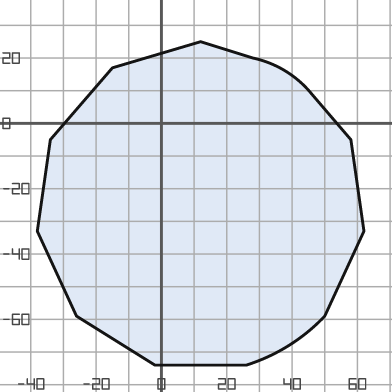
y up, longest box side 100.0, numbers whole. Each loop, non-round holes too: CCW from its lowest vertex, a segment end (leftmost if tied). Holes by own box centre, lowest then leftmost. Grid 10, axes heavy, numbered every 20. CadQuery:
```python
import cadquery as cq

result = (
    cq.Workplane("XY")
    .moveTo(-2.0, -74.0)
    .lineTo(26.0, -74.0)
    .threePointArc((39.0, -68.0), (50.0, -59.0))
    .lineTo(62.0, -33.0)
    .lineTo(58.0, -5.0)
    .lineTo(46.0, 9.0)
    .threePointArc((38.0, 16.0), (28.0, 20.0))
    .lineTo(12.0, 25.0)
    .lineTo(-15.0, 17.0)
    .lineTo(-34.0, -5.0)
    .lineTo(-38.0, -33.0)
    .lineTo(-26.0, -59.0)
    .close()
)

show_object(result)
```